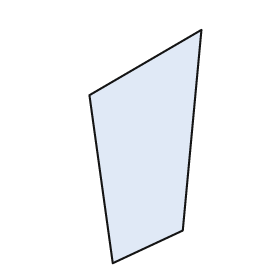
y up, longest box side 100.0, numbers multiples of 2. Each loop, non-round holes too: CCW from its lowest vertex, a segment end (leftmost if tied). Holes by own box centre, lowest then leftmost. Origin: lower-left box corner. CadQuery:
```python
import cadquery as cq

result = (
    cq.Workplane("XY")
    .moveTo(10.0, 0.0)
    .lineTo(40.0, 14.0)
    .lineTo(48.0, 100.0)
    .lineTo(0.0, 72.0)
    .close()
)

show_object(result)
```